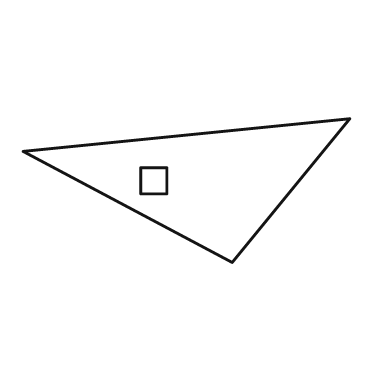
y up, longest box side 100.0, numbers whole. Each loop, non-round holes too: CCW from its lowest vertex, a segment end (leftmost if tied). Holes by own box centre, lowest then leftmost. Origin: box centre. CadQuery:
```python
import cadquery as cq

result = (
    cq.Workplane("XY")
    .moveTo(14.0, -22.0)
    .lineTo(50.0, 22.0)
    .lineTo(-50.0, 12.0)
    .close()
    .moveTo(-14.0, -1.0)
    .lineTo(-6.0, -1.0)
    .lineTo(-6.0, 7.0)
    .lineTo(-14.0, 7.0)
    .close()
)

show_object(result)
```